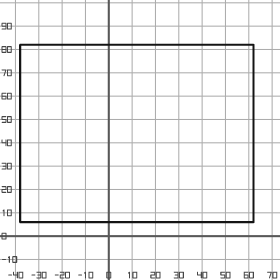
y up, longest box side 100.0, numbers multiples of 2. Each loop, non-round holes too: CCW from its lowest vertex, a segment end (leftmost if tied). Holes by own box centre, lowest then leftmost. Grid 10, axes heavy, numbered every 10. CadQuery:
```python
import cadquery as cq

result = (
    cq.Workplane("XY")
    .moveTo(-38.0, 6.0)
    .lineTo(62.0, 6.0)
    .lineTo(62.0, 82.0)
    .lineTo(-38.0, 82.0)
    .close()
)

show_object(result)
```